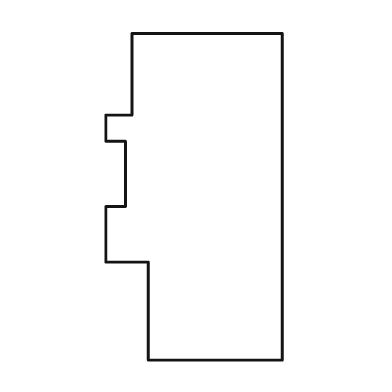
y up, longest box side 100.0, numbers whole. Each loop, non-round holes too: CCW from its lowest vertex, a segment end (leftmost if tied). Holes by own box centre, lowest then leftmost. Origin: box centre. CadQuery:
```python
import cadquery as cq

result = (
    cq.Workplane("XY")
    .moveTo(-14.0, -50.0)
    .lineTo(27.0, -50.0)
    .lineTo(27.0, 50.0)
    .lineTo(-19.0, 50.0)
    .lineTo(-19.0, 25.0)
    .lineTo(-27.0, 25.0)
    .lineTo(-27.0, 17.0)
    .lineTo(-21.0, 17.0)
    .lineTo(-21.0, -3.0)
    .lineTo(-27.0, -3.0)
    .lineTo(-27.0, -20.0)
    .lineTo(-14.0, -20.0)
    .close()
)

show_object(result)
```